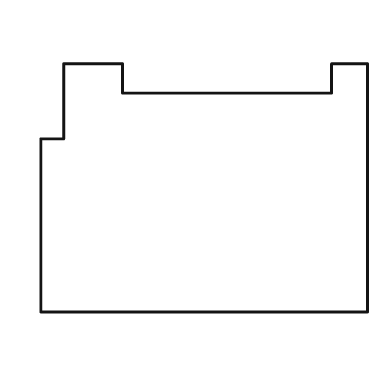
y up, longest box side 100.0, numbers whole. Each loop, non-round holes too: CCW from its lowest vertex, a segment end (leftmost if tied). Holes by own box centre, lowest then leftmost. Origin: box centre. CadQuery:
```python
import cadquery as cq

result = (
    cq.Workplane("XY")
    .moveTo(-50.0, -38.0)
    .lineTo(50.0, -38.0)
    .lineTo(50.0, 38.0)
    .lineTo(39.0, 38.0)
    .lineTo(39.0, 29.0)
    .lineTo(-25.0, 29.0)
    .lineTo(-25.0, 38.0)
    .lineTo(-43.0, 38.0)
    .lineTo(-43.0, 15.0)
    .lineTo(-50.0, 15.0)
    .close()
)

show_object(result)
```